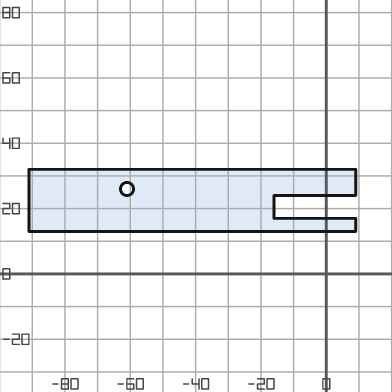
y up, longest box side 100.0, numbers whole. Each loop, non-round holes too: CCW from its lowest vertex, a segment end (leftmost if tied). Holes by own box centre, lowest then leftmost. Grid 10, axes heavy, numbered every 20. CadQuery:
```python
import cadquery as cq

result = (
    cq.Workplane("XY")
    .moveTo(-91.0, 13.0)
    .lineTo(9.0, 13.0)
    .lineTo(9.0, 17.0)
    .lineTo(-16.0, 17.0)
    .lineTo(-16.0, 24.0)
    .lineTo(9.0, 24.0)
    .lineTo(9.0, 32.0)
    .lineTo(-91.0, 32.0)
    .close()
    .moveTo(-61.0, 26.0)
    .circle(2.0)
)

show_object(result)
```